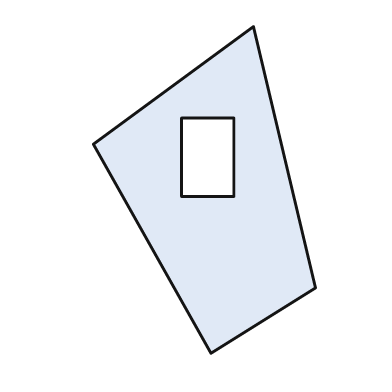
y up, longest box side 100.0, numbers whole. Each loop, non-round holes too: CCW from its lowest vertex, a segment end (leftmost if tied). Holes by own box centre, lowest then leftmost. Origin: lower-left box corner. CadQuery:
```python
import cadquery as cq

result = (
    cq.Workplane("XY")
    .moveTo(36.0, 0.0)
    .lineTo(68.0, 20.0)
    .lineTo(49.0, 100.0)
    .lineTo(0.0, 64.0)
    .close()
    .moveTo(27.0, 48.0)
    .lineTo(43.0, 48.0)
    .lineTo(43.0, 72.0)
    .lineTo(27.0, 72.0)
    .close()
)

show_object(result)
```